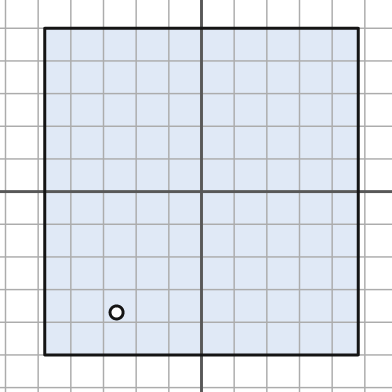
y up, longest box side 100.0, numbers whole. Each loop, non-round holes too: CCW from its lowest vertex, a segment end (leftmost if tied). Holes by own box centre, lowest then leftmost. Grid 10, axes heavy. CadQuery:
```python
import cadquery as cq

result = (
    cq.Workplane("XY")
    .moveTo(-48.0, -50.0)
    .lineTo(48.0, -50.0)
    .lineTo(48.0, 50.0)
    .lineTo(-48.0, 50.0)
    .close()
    .moveTo(-26.0, -37.0)
    .circle(2.0)
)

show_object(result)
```